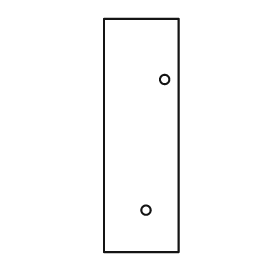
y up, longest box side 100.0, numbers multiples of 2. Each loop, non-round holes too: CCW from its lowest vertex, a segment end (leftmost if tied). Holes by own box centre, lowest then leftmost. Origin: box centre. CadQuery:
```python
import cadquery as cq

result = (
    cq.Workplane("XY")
    .moveTo(-16.0, -50.0)
    .lineTo(16.0, -50.0)
    .lineTo(16.0, 50.0)
    .lineTo(-16.0, 50.0)
    .close()
    .moveTo(2.0, -32.0)
    .circle(2.0)
    .moveTo(10.0, 24.0)
    .circle(2.0)
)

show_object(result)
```